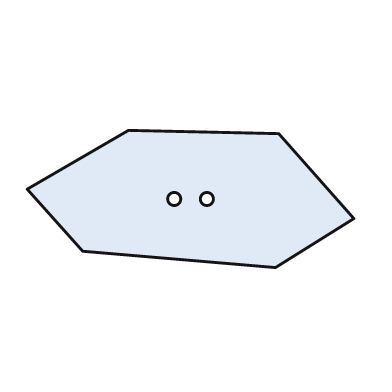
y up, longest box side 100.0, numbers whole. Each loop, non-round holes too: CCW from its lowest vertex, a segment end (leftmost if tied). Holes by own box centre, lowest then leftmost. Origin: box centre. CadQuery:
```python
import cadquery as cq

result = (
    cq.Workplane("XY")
    .moveTo(26.0, -21.0)
    .lineTo(50.0, -6.0)
    .lineTo(27.0, 20.0)
    .lineTo(-19.0, 21.0)
    .lineTo(-50.0, 3.0)
    .lineTo(-33.0, -16.0)
    .close()
    .moveTo(-5.0, 0.0)
    .circle(2.0)
    .moveTo(5.0, 0.0)
    .circle(2.0)
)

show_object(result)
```